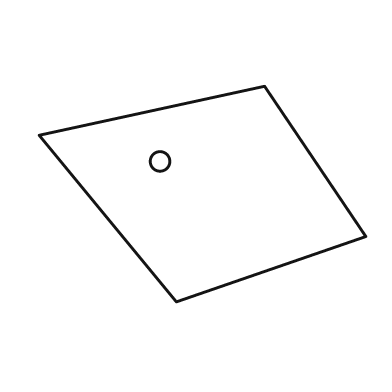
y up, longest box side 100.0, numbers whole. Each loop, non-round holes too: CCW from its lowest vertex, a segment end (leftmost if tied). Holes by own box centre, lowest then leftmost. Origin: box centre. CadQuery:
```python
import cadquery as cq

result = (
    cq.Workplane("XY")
    .moveTo(-8.0, -33.0)
    .lineTo(50.0, -13.0)
    .lineTo(19.0, 33.0)
    .lineTo(-50.0, 18.0)
    .close()
    .moveTo(-13.0, 10.0)
    .circle(3.0)
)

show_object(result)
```